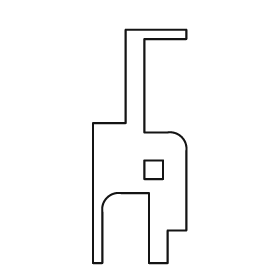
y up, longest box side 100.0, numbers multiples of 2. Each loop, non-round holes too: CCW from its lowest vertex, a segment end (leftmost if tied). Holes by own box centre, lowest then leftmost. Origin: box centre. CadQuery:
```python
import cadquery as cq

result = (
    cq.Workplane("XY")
    .moveTo(-20.0, -50.0)
    .lineTo(-16.0, -50.0)
    .lineTo(-16.0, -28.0)
    .threePointArc((-14.0, -22.0), (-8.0, -20.0))
    .lineTo(4.0, -20.0)
    .lineTo(4.0, -50.0)
    .lineTo(12.0, -50.0)
    .lineTo(12.0, -36.0)
    .lineTo(20.0, -36.0)
    .lineTo(20.0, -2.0)
    .threePointArc((18.0, 4.0), (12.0, 6.0))
    .lineTo(2.0, 6.0)
    .lineTo(2.0, 46.0)
    .lineTo(20.0, 46.0)
    .lineTo(20.0, 50.0)
    .lineTo(-6.0, 50.0)
    .lineTo(-6.0, 10.0)
    .lineTo(-20.0, 10.0)
    .close()
    .moveTo(2.0, -14.0)
    .lineTo(10.0, -14.0)
    .lineTo(10.0, -6.0)
    .lineTo(2.0, -6.0)
    .close()
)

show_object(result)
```